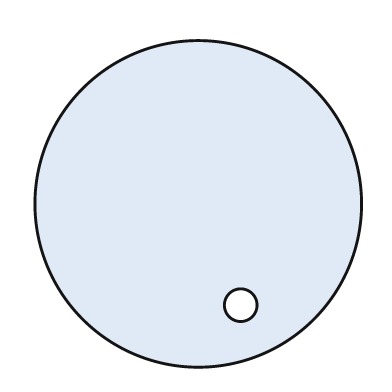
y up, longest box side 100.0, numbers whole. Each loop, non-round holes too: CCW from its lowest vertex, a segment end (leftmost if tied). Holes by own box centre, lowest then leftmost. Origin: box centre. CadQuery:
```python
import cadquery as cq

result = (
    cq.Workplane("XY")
    .moveTo(0.0, 0.0)
    .circle(50.0)
    .moveTo(13.0, -31.0)
    .circle(5.0)
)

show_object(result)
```